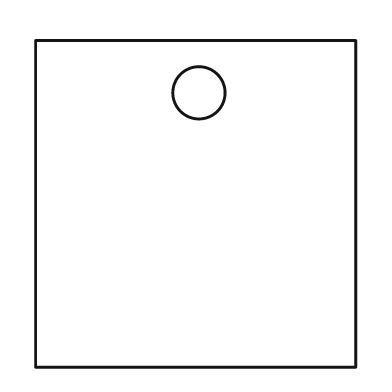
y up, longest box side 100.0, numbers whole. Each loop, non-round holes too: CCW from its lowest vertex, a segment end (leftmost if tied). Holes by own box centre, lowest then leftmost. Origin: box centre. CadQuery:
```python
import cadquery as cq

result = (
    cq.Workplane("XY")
    .moveTo(-49.0, -50.0)
    .lineTo(49.0, -50.0)
    .lineTo(49.0, 50.0)
    .lineTo(-49.0, 50.0)
    .close()
    .moveTo(1.0, 34.0)
    .circle(8.0)
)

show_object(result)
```